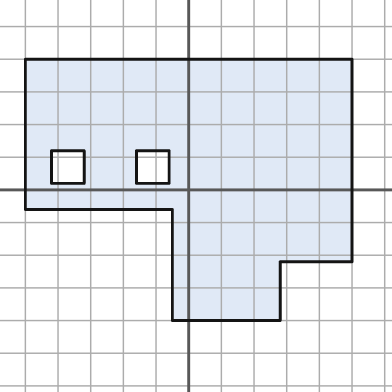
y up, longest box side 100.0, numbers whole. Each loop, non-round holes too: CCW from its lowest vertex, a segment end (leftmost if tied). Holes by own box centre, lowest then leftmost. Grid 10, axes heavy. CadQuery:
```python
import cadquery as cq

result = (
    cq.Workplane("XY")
    .moveTo(-5.0, -40.0)
    .lineTo(28.0, -40.0)
    .lineTo(28.0, -22.0)
    .lineTo(50.0, -22.0)
    .lineTo(50.0, 40.0)
    .lineTo(-50.0, 40.0)
    .lineTo(-50.0, -6.0)
    .lineTo(-5.0, -6.0)
    .close()
    .moveTo(-42.0, 2.0)
    .lineTo(-32.0, 2.0)
    .lineTo(-32.0, 12.0)
    .lineTo(-42.0, 12.0)
    .close()
    .moveTo(-16.0, 2.0)
    .lineTo(-6.0, 2.0)
    .lineTo(-6.0, 12.0)
    .lineTo(-16.0, 12.0)
    .close()
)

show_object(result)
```